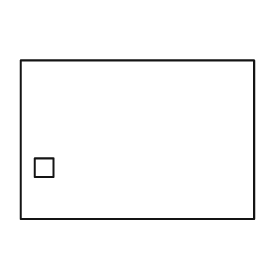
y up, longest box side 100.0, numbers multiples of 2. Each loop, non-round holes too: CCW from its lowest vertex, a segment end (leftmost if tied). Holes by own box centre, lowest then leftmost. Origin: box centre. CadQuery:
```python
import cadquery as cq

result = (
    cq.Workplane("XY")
    .moveTo(-50.0, -34.0)
    .lineTo(50.0, -34.0)
    .lineTo(50.0, 34.0)
    .lineTo(-50.0, 34.0)
    .close()
    .moveTo(-44.0, -16.0)
    .lineTo(-36.0, -16.0)
    .lineTo(-36.0, -8.0)
    .lineTo(-44.0, -8.0)
    .close()
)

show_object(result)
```